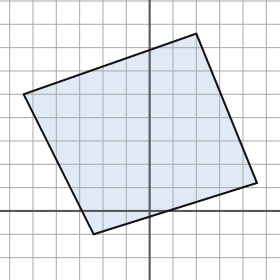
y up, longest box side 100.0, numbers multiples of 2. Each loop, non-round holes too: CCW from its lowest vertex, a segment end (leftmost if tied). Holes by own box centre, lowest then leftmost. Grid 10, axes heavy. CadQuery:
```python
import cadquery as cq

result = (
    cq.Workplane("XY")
    .moveTo(-24.0, -10.0)
    .lineTo(46.0, 12.0)
    .lineTo(20.0, 76.0)
    .lineTo(-54.0, 50.0)
    .close()
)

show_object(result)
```